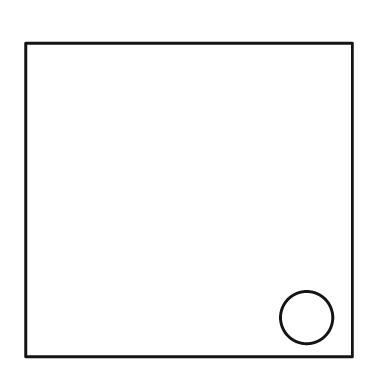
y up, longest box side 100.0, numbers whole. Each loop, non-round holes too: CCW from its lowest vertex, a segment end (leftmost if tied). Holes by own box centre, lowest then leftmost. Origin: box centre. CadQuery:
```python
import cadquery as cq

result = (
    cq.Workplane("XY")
    .moveTo(-50.0, -48.0)
    .lineTo(50.0, -48.0)
    .lineTo(50.0, 48.0)
    .lineTo(-50.0, 48.0)
    .close()
    .moveTo(36.0, -36.0)
    .circle(8.0)
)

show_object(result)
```